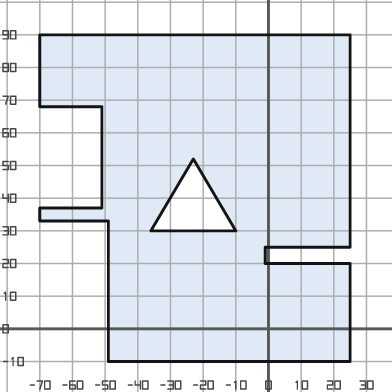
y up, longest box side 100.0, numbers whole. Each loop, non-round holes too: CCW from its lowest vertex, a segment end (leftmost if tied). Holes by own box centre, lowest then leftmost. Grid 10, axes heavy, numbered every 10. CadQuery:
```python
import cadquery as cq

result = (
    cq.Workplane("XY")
    .moveTo(-49.0, -10.0)
    .lineTo(25.0, -10.0)
    .lineTo(25.0, 20.0)
    .lineTo(-1.0, 20.0)
    .lineTo(-1.0, 25.0)
    .lineTo(25.0, 25.0)
    .lineTo(25.0, 90.0)
    .lineTo(-70.0, 90.0)
    .lineTo(-70.0, 68.0)
    .lineTo(-51.0, 68.0)
    .lineTo(-51.0, 37.0)
    .lineTo(-70.0, 37.0)
    .lineTo(-70.0, 33.0)
    .lineTo(-49.0, 33.0)
    .close()
    .moveTo(-36.0, 30.0)
    .lineTo(-10.0, 30.0)
    .lineTo(-23.0, 52.0)
    .close()
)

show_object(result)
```